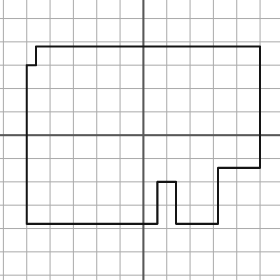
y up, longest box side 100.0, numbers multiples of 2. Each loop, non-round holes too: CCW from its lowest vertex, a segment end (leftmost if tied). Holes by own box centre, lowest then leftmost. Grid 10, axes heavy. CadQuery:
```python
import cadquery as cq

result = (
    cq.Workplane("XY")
    .moveTo(-50.0, -38.0)
    .lineTo(6.0, -38.0)
    .lineTo(6.0, -20.0)
    .lineTo(14.0, -20.0)
    .lineTo(14.0, -38.0)
    .lineTo(32.0, -38.0)
    .lineTo(32.0, -14.0)
    .lineTo(50.0, -14.0)
    .lineTo(50.0, 38.0)
    .lineTo(-46.0, 38.0)
    .lineTo(-46.0, 30.0)
    .lineTo(-50.0, 30.0)
    .close()
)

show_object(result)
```